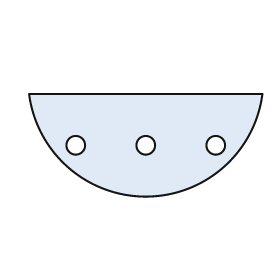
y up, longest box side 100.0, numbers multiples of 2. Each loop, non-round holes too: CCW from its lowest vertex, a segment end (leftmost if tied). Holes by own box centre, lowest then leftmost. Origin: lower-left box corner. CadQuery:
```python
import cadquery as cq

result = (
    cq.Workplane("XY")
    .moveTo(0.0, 44.0)
    .threePointArc((50.0, 0.0), (100.0, 44.0))
    .close()
    .moveTo(20.0, 22.0)
    .circle(4.0)
    .moveTo(50.0, 22.0)
    .circle(4.0)
    .moveTo(80.0, 22.0)
    .circle(4.0)
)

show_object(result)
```